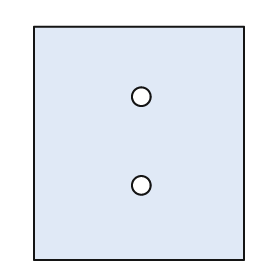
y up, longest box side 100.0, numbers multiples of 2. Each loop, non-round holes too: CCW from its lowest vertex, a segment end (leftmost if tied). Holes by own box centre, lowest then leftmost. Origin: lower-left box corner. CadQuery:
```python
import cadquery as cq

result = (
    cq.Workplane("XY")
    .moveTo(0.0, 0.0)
    .lineTo(90.0, 0.0)
    .lineTo(90.0, 100.0)
    .lineTo(0.0, 100.0)
    .close()
    .moveTo(46.0, 32.0)
    .circle(4.0)
    .moveTo(46.0, 70.0)
    .circle(4.0)
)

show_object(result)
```